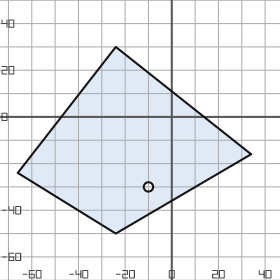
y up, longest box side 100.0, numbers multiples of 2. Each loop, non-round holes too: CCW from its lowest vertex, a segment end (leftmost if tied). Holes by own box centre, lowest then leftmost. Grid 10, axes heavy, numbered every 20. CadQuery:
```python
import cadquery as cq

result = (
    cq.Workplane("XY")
    .moveTo(-24.0, -50.0)
    .lineTo(34.0, -16.0)
    .lineTo(-24.0, 30.0)
    .lineTo(-66.0, -24.0)
    .close()
    .moveTo(-10.0, -30.0)
    .circle(2.0)
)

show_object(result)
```